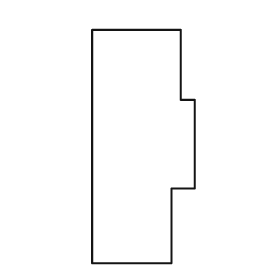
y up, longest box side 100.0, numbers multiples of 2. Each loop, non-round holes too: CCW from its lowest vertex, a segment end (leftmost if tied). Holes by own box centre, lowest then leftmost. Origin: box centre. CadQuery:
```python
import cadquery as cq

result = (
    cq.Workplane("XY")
    .moveTo(-22.0, -50.0)
    .lineTo(12.0, -50.0)
    .lineTo(12.0, -18.0)
    .lineTo(22.0, -18.0)
    .lineTo(22.0, 20.0)
    .lineTo(16.0, 20.0)
    .lineTo(16.0, 50.0)
    .lineTo(-22.0, 50.0)
    .close()
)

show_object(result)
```